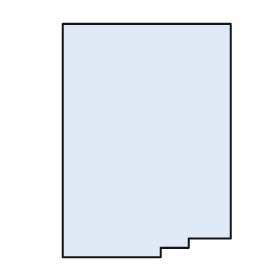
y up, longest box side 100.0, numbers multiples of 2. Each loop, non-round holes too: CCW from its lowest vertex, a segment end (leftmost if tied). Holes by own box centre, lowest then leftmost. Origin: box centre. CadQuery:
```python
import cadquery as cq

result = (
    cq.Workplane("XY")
    .moveTo(-36.0, -50.0)
    .lineTo(6.0, -50.0)
    .lineTo(6.0, -46.0)
    .lineTo(18.0, -46.0)
    .lineTo(18.0, -42.0)
    .lineTo(36.0, -42.0)
    .lineTo(36.0, 50.0)
    .lineTo(-36.0, 50.0)
    .close()
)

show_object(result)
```